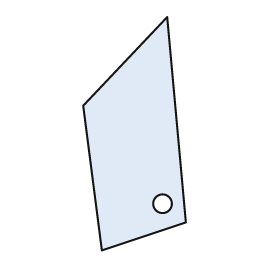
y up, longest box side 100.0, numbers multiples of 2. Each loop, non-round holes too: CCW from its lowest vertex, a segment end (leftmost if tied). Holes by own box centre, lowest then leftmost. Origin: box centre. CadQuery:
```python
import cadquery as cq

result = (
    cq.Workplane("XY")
    .moveTo(-14.0, -50.0)
    .lineTo(22.0, -38.0)
    .lineTo(14.0, 50.0)
    .lineTo(-22.0, 12.0)
    .close()
    .moveTo(12.0, -30.0)
    .circle(4.0)
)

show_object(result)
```